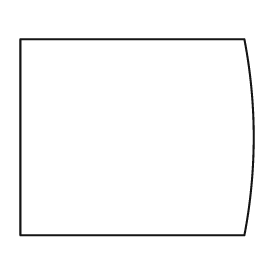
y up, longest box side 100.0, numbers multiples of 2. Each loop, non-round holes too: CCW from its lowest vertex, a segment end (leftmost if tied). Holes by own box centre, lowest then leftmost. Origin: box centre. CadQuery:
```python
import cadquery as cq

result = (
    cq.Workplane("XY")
    .moveTo(-50.0, -42.0)
    .lineTo(46.0, -42.0)
    .threePointArc((50.0, 0.0), (46.0, 42.0))
    .lineTo(-50.0, 42.0)
    .close()
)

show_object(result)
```